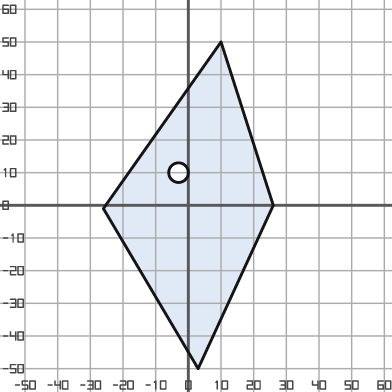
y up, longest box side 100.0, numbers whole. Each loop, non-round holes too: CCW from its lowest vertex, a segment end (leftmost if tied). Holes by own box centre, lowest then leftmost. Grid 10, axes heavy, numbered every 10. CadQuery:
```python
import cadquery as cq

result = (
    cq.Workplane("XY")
    .moveTo(3.0, -50.0)
    .lineTo(26.0, 0.0)
    .lineTo(10.0, 50.0)
    .lineTo(-26.0, -1.0)
    .close()
    .moveTo(-3.0, 10.0)
    .circle(3.0)
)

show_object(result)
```